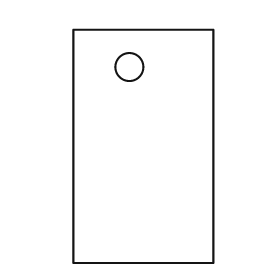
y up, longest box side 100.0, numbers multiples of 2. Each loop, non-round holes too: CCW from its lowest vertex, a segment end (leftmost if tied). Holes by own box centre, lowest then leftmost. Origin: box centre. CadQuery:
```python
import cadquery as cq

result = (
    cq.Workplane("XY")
    .moveTo(-30.0, -50.0)
    .lineTo(30.0, -50.0)
    .lineTo(30.0, 50.0)
    .lineTo(-30.0, 50.0)
    .close()
    .moveTo(-6.0, 34.0)
    .circle(6.0)
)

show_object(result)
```